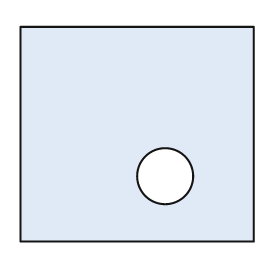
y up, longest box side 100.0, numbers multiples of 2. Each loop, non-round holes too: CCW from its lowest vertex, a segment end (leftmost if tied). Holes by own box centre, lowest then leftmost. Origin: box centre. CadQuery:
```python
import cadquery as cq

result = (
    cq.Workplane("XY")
    .moveTo(-50.0, -46.0)
    .lineTo(50.0, -46.0)
    .lineTo(50.0, 46.0)
    .lineTo(-50.0, 46.0)
    .close()
    .moveTo(12.0, -18.0)
    .circle(12.0)
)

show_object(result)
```